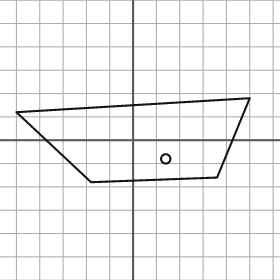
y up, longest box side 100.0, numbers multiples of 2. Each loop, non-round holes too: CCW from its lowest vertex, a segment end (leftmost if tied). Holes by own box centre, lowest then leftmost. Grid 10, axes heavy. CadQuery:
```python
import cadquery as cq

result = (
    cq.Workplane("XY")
    .moveTo(-18.0, -18.0)
    .lineTo(36.0, -16.0)
    .lineTo(50.0, 18.0)
    .lineTo(-50.0, 12.0)
    .close()
    .moveTo(14.0, -8.0)
    .circle(2.0)
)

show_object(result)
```